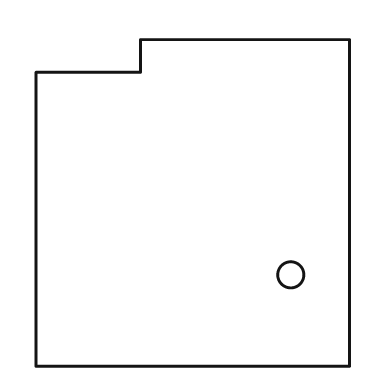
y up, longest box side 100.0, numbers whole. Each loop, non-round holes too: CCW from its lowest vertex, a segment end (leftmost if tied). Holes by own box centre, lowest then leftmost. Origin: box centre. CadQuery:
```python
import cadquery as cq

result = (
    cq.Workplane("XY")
    .moveTo(-48.0, -50.0)
    .lineTo(48.0, -50.0)
    .lineTo(48.0, 50.0)
    .lineTo(-16.0, 50.0)
    .lineTo(-16.0, 40.0)
    .lineTo(-48.0, 40.0)
    .close()
    .moveTo(30.0, -22.0)
    .circle(4.0)
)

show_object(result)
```